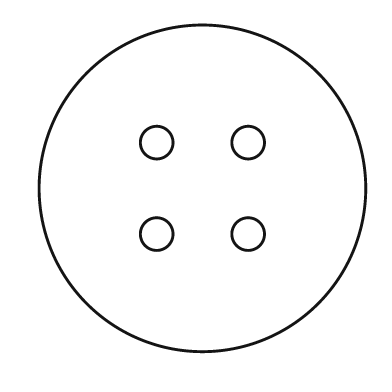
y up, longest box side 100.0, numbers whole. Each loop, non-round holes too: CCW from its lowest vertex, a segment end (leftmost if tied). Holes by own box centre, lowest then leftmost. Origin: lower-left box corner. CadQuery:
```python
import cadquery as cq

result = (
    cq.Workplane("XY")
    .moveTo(50.0, 50.0)
    .circle(50.0)
    .moveTo(36.0, 36.0)
    .circle(5.0)
    .moveTo(64.0, 36.0)
    .circle(5.0)
    .moveTo(36.0, 64.0)
    .circle(5.0)
    .moveTo(64.0, 64.0)
    .circle(5.0)
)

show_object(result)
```